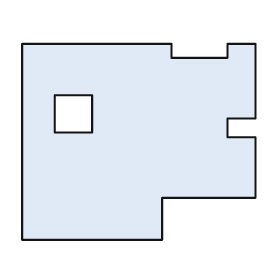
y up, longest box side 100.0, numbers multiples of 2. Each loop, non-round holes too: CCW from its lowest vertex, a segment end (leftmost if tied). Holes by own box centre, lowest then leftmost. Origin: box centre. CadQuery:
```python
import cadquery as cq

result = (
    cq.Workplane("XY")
    .moveTo(-50.0, -42.0)
    .lineTo(10.0, -42.0)
    .lineTo(10.0, -24.0)
    .lineTo(50.0, -24.0)
    .lineTo(50.0, 2.0)
    .lineTo(38.0, 2.0)
    .lineTo(38.0, 10.0)
    .lineTo(50.0, 10.0)
    .lineTo(50.0, 42.0)
    .lineTo(38.0, 42.0)
    .lineTo(38.0, 36.0)
    .lineTo(14.0, 36.0)
    .lineTo(14.0, 42.0)
    .lineTo(-50.0, 42.0)
    .close()
    .moveTo(-36.0, 4.0)
    .lineTo(-20.0, 4.0)
    .lineTo(-20.0, 20.0)
    .lineTo(-36.0, 20.0)
    .close()
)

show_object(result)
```